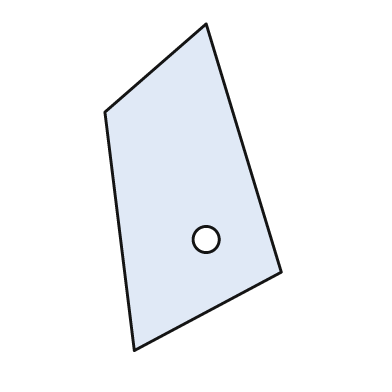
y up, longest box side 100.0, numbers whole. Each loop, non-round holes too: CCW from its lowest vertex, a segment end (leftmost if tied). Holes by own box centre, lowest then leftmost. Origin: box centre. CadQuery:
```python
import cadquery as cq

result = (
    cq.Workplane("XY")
    .moveTo(-18.0, -50.0)
    .lineTo(27.0, -26.0)
    .lineTo(4.0, 50.0)
    .lineTo(-27.0, 23.0)
    .close()
    .moveTo(4.0, -16.0)
    .circle(4.0)
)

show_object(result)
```